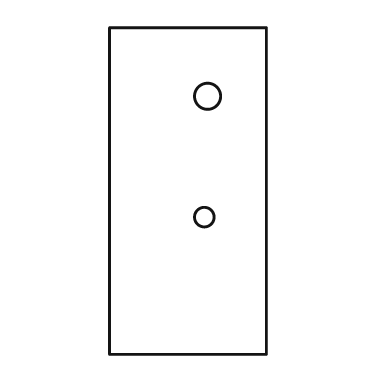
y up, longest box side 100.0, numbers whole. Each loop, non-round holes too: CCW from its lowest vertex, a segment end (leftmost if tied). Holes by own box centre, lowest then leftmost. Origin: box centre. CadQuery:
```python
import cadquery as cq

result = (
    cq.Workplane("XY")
    .moveTo(-24.0, -50.0)
    .lineTo(24.0, -50.0)
    .lineTo(24.0, 50.0)
    .lineTo(-24.0, 50.0)
    .close()
    .moveTo(5.0, -8.0)
    .circle(3.0)
    .moveTo(6.0, 29.0)
    .circle(4.0)
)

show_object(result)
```